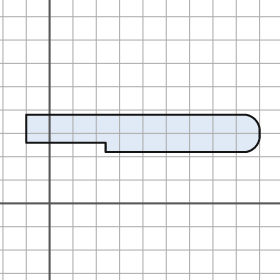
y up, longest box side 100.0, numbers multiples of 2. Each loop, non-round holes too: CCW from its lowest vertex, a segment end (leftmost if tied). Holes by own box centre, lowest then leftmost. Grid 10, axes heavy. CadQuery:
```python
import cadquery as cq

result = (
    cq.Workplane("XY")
    .moveTo(24.0, 22.0)
    .lineTo(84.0, 22.0)
    .threePointArc((88.0, 24.0), (90.0, 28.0))
    .lineTo(90.0, 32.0)
    .threePointArc((88.0, 36.0), (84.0, 38.0))
    .lineTo(-10.0, 38.0)
    .lineTo(-10.0, 26.0)
    .lineTo(24.0, 26.0)
    .close()
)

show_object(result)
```